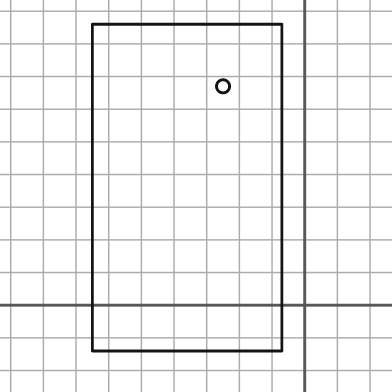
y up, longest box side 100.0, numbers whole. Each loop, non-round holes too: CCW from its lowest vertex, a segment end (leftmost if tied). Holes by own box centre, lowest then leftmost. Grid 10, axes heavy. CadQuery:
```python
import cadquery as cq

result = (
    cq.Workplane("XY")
    .moveTo(-65.0, -14.0)
    .lineTo(-7.0, -14.0)
    .lineTo(-7.0, 86.0)
    .lineTo(-65.0, 86.0)
    .close()
    .moveTo(-25.0, 67.0)
    .circle(2.0)
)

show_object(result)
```